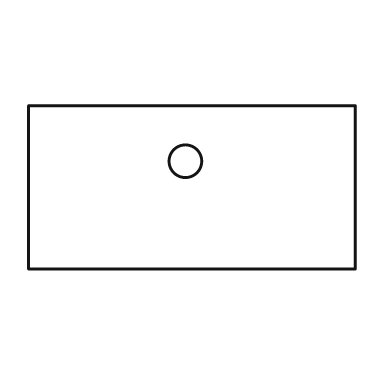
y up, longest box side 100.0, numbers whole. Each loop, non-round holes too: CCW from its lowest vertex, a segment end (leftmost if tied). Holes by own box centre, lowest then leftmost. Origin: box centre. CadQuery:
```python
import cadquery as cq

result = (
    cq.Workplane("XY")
    .moveTo(-50.0, -25.0)
    .lineTo(50.0, -25.0)
    .lineTo(50.0, 25.0)
    .lineTo(-50.0, 25.0)
    .close()
    .moveTo(-2.0, 8.0)
    .circle(5.0)
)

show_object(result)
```